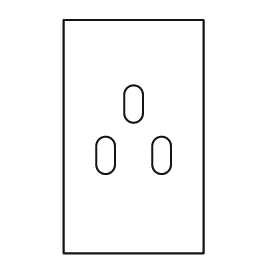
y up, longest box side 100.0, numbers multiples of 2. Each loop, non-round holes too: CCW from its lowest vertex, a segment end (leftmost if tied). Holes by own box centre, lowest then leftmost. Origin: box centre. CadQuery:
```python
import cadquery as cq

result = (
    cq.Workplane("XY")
    .moveTo(-30.0, -50.0)
    .lineTo(30.0, -50.0)
    .lineTo(30.0, 50.0)
    .lineTo(-30.0, 50.0)
    .close()
    .moveTo(-16.0, -12.0)
    .threePointArc((-12.0, -16.0), (-8.0, -12.0))
    .lineTo(-8.0, -4.0)
    .threePointArc((-12.0, 0.0), (-16.0, -4.0))
    .close()
    .moveTo(8.0, -12.0)
    .threePointArc((12.0, -16.0), (16.0, -12.0))
    .lineTo(16.0, -4.0)
    .threePointArc((12.0, 0.0), (8.0, -4.0))
    .close()
    .moveTo(-4.0, 10.0)
    .threePointArc((0.0, 6.0), (4.0, 10.0))
    .lineTo(4.0, 18.0)
    .threePointArc((0.0, 22.0), (-4.0, 18.0))
    .close()
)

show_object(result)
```